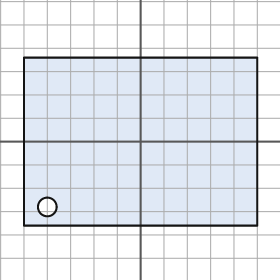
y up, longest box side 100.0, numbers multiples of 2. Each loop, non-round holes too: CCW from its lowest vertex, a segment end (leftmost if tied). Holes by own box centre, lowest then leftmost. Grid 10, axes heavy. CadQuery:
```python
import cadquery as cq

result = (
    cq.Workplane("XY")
    .moveTo(-50.0, -36.0)
    .lineTo(50.0, -36.0)
    .lineTo(50.0, 36.0)
    .lineTo(-50.0, 36.0)
    .close()
    .moveTo(-40.0, -28.0)
    .circle(4.0)
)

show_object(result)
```